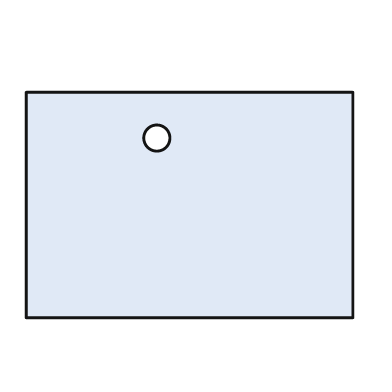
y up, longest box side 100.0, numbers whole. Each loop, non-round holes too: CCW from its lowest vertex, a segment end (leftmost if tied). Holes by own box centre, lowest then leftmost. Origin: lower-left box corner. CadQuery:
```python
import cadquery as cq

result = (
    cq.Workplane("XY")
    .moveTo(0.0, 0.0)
    .lineTo(100.0, 0.0)
    .lineTo(100.0, 69.0)
    .lineTo(0.0, 69.0)
    .close()
    .moveTo(40.0, 55.0)
    .circle(4.0)
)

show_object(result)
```